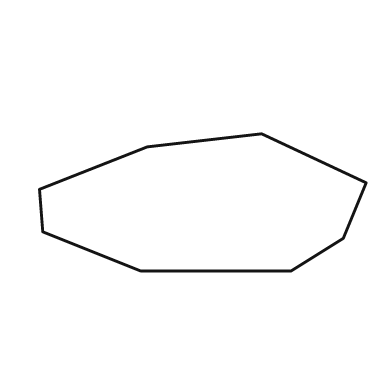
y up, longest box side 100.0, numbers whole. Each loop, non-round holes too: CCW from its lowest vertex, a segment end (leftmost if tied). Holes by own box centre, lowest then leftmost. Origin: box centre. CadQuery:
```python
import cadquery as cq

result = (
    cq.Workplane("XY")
    .moveTo(-19.0, -21.0)
    .lineTo(27.0, -21.0)
    .lineTo(43.0, -11.0)
    .lineTo(50.0, 6.0)
    .lineTo(18.0, 21.0)
    .lineTo(-17.0, 17.0)
    .lineTo(-50.0, 4.0)
    .lineTo(-49.0, -9.0)
    .close()
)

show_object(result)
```